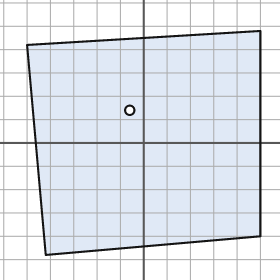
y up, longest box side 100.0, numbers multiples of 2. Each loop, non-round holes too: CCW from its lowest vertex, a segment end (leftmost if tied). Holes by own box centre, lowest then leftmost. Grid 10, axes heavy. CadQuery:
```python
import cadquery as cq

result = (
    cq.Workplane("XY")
    .moveTo(-42.0, -48.0)
    .lineTo(50.0, -40.0)
    .lineTo(50.0, 48.0)
    .lineTo(-50.0, 42.0)
    .close()
    .moveTo(-6.0, 14.0)
    .circle(2.0)
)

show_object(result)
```